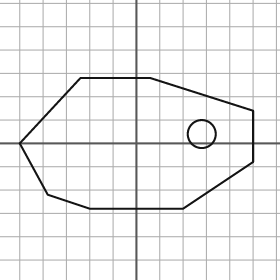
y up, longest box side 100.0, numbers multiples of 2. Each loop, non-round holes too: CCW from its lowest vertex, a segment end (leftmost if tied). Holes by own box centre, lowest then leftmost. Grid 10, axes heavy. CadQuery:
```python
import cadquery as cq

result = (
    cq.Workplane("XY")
    .moveTo(-20.0, -28.0)
    .lineTo(20.0, -28.0)
    .lineTo(50.0, -8.0)
    .lineTo(50.0, 14.0)
    .lineTo(6.0, 28.0)
    .lineTo(-24.0, 28.0)
    .lineTo(-50.0, 0.0)
    .lineTo(-38.0, -22.0)
    .close()
    .moveTo(28.0, 4.0)
    .circle(6.0)
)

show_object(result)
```